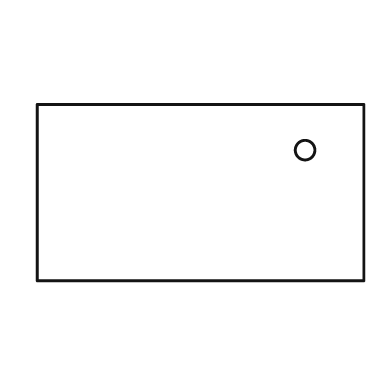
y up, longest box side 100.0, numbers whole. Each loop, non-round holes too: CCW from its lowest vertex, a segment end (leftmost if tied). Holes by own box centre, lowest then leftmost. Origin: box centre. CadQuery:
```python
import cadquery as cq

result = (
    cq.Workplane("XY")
    .moveTo(-50.0, -27.0)
    .lineTo(50.0, -27.0)
    .lineTo(50.0, 27.0)
    .lineTo(-50.0, 27.0)
    .close()
    .moveTo(32.0, 13.0)
    .circle(3.0)
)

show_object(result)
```